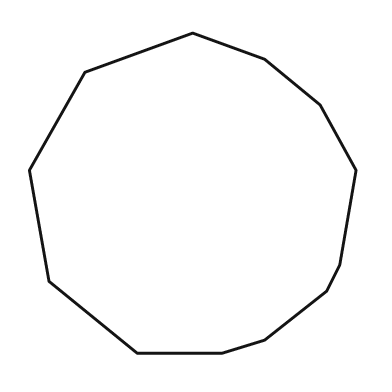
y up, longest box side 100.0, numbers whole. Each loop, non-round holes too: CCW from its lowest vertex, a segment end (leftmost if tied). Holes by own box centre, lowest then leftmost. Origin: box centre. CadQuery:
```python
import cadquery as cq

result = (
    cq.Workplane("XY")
    .moveTo(-17.0, -49.0)
    .lineTo(9.0, -49.0)
    .lineTo(22.0, -45.0)
    .lineTo(41.0, -30.0)
    .lineTo(45.0, -22.0)
    .lineTo(50.0, 7.0)
    .lineTo(39.0, 27.0)
    .lineTo(22.0, 41.0)
    .lineTo(0.0, 49.0)
    .lineTo(-33.0, 37.0)
    .lineTo(-50.0, 7.0)
    .lineTo(-44.0, -27.0)
    .close()
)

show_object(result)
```